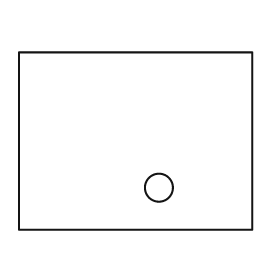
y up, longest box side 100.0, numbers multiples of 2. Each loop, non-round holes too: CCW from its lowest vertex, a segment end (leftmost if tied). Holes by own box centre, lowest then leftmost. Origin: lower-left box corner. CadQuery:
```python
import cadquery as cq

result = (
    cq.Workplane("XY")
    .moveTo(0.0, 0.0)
    .lineTo(100.0, 0.0)
    .lineTo(100.0, 76.0)
    .lineTo(0.0, 76.0)
    .close()
    .moveTo(60.0, 18.0)
    .circle(6.0)
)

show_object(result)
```